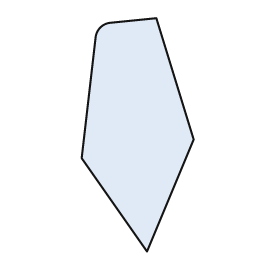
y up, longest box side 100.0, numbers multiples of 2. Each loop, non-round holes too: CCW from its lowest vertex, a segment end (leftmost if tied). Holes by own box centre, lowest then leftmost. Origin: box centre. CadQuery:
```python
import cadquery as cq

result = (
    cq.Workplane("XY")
    .moveTo(4.0, -50.0)
    .lineTo(24.0, -2.0)
    .lineTo(8.0, 50.0)
    .lineTo(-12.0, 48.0)
    .threePointArc((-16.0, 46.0), (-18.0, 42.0))
    .lineTo(-24.0, -10.0)
    .close()
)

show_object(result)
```